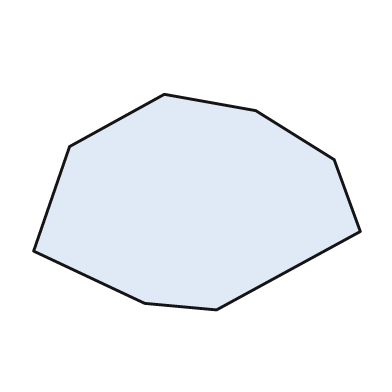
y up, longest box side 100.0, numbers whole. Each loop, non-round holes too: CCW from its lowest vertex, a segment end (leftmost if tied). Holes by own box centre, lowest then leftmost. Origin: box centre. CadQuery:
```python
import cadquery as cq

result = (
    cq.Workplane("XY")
    .moveTo(6.0, -33.0)
    .lineTo(50.0, -9.0)
    .lineTo(42.0, 13.0)
    .lineTo(18.0, 28.0)
    .lineTo(-10.0, 33.0)
    .lineTo(-39.0, 17.0)
    .lineTo(-50.0, -15.0)
    .lineTo(-16.0, -31.0)
    .close()
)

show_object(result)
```